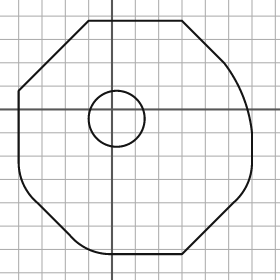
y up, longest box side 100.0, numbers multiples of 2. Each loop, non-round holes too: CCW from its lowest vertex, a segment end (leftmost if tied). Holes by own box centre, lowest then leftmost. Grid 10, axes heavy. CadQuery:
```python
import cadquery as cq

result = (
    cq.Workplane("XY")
    .moveTo(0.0, -62.0)
    .lineTo(30.0, -62.0)
    .lineTo(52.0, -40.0)
    .threePointArc((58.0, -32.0), (60.0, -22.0))
    .lineTo(60.0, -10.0)
    .threePointArc((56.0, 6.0), (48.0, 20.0))
    .lineTo(30.0, 38.0)
    .lineTo(-10.0, 38.0)
    .lineTo(-40.0, 8.0)
    .lineTo(-40.0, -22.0)
    .threePointArc((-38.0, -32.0), (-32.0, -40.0))
    .lineTo(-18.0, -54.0)
    .threePointArc((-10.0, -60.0), (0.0, -62.0))
    .close()
    .moveTo(2.0, -4.0)
    .circle(12.0)
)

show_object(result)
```